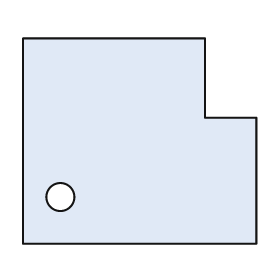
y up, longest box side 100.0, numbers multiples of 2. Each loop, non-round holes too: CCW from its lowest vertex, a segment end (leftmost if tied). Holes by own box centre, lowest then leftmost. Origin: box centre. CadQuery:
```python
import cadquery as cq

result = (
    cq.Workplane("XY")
    .moveTo(-50.0, -44.0)
    .lineTo(50.0, -44.0)
    .lineTo(50.0, 10.0)
    .lineTo(28.0, 10.0)
    .lineTo(28.0, 44.0)
    .lineTo(-50.0, 44.0)
    .close()
    .moveTo(-34.0, -24.0)
    .circle(6.0)
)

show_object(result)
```